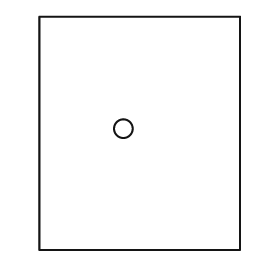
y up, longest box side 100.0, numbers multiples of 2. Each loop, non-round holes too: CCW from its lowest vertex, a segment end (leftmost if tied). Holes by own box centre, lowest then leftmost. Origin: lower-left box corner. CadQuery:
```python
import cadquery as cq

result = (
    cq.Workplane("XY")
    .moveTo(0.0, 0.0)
    .lineTo(86.0, 0.0)
    .lineTo(86.0, 100.0)
    .lineTo(0.0, 100.0)
    .close()
    .moveTo(36.0, 52.0)
    .circle(4.0)
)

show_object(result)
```